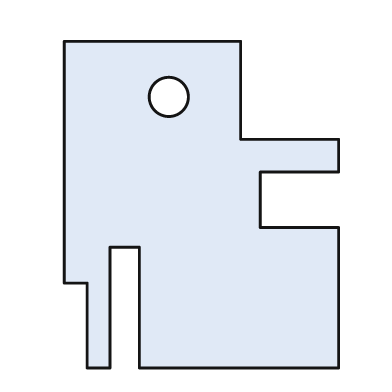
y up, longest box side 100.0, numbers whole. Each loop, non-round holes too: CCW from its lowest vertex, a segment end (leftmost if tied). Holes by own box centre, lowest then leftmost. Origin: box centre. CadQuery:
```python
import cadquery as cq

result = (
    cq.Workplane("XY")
    .moveTo(-35.0, -50.0)
    .lineTo(-28.0, -50.0)
    .lineTo(-28.0, -13.0)
    .lineTo(-19.0, -13.0)
    .lineTo(-19.0, -50.0)
    .lineTo(42.0, -50.0)
    .lineTo(42.0, -7.0)
    .lineTo(18.0, -7.0)
    .lineTo(18.0, 10.0)
    .lineTo(42.0, 10.0)
    .lineTo(42.0, 20.0)
    .lineTo(12.0, 20.0)
    .lineTo(12.0, 50.0)
    .lineTo(-42.0, 50.0)
    .lineTo(-42.0, -24.0)
    .lineTo(-35.0, -24.0)
    .close()
    .moveTo(-10.0, 33.0)
    .circle(6.0)
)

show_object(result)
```